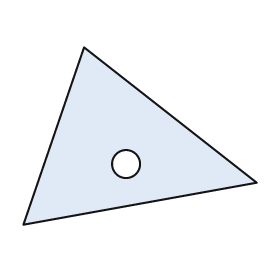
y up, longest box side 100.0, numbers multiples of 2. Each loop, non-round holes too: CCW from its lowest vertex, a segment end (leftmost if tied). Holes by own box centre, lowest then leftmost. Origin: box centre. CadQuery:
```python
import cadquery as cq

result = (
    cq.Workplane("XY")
    .moveTo(-50.0, -38.0)
    .lineTo(50.0, -20.0)
    .lineTo(-24.0, 38.0)
    .close()
    .moveTo(-6.0, -12.0)
    .circle(6.0)
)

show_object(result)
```